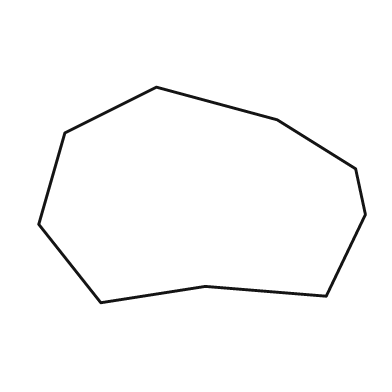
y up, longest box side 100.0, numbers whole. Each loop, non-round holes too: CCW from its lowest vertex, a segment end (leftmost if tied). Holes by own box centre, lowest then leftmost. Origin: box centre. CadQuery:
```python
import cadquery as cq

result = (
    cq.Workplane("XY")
    .moveTo(-31.0, -33.0)
    .lineTo(1.0, -28.0)
    .lineTo(38.0, -31.0)
    .lineTo(50.0, -6.0)
    .lineTo(47.0, 8.0)
    .lineTo(23.0, 23.0)
    .lineTo(-14.0, 33.0)
    .lineTo(-42.0, 19.0)
    .lineTo(-50.0, -9.0)
    .close()
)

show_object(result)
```